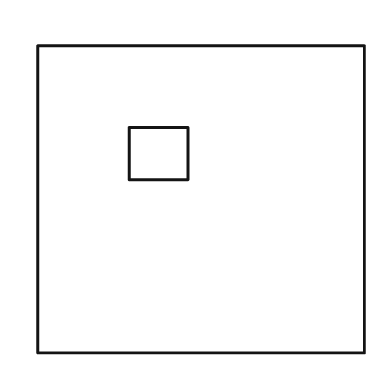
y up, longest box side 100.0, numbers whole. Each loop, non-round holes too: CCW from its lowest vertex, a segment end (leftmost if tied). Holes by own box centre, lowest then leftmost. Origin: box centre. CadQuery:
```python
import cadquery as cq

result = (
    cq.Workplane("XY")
    .moveTo(-50.0, -47.0)
    .lineTo(50.0, -47.0)
    .lineTo(50.0, 47.0)
    .lineTo(-50.0, 47.0)
    .close()
    .moveTo(-22.0, 6.0)
    .lineTo(-4.0, 6.0)
    .lineTo(-4.0, 22.0)
    .lineTo(-22.0, 22.0)
    .close()
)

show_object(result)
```